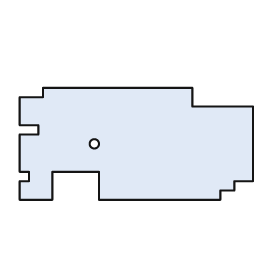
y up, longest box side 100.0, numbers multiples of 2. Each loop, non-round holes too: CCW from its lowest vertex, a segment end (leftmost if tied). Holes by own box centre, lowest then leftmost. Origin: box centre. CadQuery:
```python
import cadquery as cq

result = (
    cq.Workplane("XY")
    .moveTo(-50.0, -24.0)
    .lineTo(-36.0, -24.0)
    .lineTo(-36.0, -12.0)
    .lineTo(-16.0, -12.0)
    .lineTo(-16.0, -24.0)
    .lineTo(36.0, -24.0)
    .lineTo(36.0, -20.0)
    .lineTo(42.0, -20.0)
    .lineTo(42.0, -16.0)
    .lineTo(50.0, -16.0)
    .lineTo(50.0, 16.0)
    .lineTo(24.0, 16.0)
    .lineTo(24.0, 24.0)
    .lineTo(-40.0, 24.0)
    .lineTo(-40.0, 20.0)
    .lineTo(-50.0, 20.0)
    .lineTo(-50.0, 8.0)
    .lineTo(-42.0, 8.0)
    .lineTo(-42.0, 4.0)
    .lineTo(-50.0, 4.0)
    .lineTo(-50.0, -12.0)
    .lineTo(-46.0, -12.0)
    .lineTo(-46.0, -16.0)
    .lineTo(-50.0, -16.0)
    .close()
    .moveTo(-18.0, 0.0)
    .circle(2.0)
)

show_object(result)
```